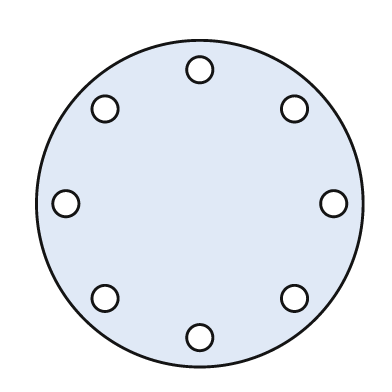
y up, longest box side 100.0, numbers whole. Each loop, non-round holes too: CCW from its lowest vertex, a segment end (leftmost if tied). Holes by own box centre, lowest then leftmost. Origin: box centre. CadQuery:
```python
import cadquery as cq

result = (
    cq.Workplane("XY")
    .moveTo(0.0, 0.0)
    .circle(50.0)
    .moveTo(0.0, -41.0)
    .circle(4.0)
    .moveTo(-29.0, -29.0)
    .circle(4.0)
    .moveTo(29.0, -29.0)
    .circle(4.0)
    .moveTo(-41.0, 0.0)
    .circle(4.0)
    .moveTo(41.0, 0.0)
    .circle(4.0)
    .moveTo(-29.0, 29.0)
    .circle(4.0)
    .moveTo(29.0, 29.0)
    .circle(4.0)
    .moveTo(0.0, 41.0)
    .circle(4.0)
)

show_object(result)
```